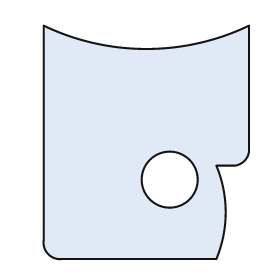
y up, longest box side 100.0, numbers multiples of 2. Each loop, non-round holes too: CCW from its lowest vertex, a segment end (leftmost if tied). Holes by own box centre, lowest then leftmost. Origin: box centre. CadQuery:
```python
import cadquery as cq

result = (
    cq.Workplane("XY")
    .moveTo(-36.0, -50.0)
    .lineTo(30.0, -50.0)
    .threePointArc((34.0, -30.0), (30.0, -10.0))
    .lineTo(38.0, -10.0)
    .threePointArc((42.0, -8.0), (44.0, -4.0))
    .lineTo(44.0, 50.0)
    .threePointArc((0.0, 40.0), (-44.0, 50.0))
    .lineTo(-44.0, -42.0)
    .threePointArc((-42.0, -48.0), (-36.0, -50.0))
    .close()
    .moveTo(10.0, -16.0)
    .circle(12.0)
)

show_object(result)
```